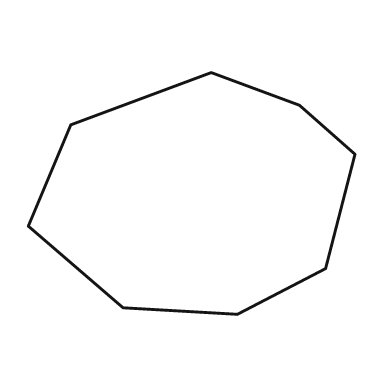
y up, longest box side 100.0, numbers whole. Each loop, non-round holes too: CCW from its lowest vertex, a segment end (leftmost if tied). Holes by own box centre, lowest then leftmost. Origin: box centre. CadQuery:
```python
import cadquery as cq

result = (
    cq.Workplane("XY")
    .moveTo(14.0, -37.0)
    .lineTo(41.0, -23.0)
    .lineTo(50.0, 12.0)
    .lineTo(33.0, 27.0)
    .lineTo(6.0, 37.0)
    .lineTo(-37.0, 21.0)
    .lineTo(-50.0, -10.0)
    .lineTo(-21.0, -35.0)
    .close()
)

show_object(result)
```